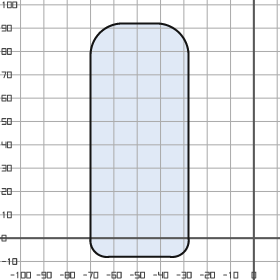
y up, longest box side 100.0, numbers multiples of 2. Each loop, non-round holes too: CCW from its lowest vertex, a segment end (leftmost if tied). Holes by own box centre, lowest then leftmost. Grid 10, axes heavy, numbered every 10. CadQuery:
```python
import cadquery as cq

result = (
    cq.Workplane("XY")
    .moveTo(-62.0, -8.0)
    .lineTo(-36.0, -8.0)
    .threePointArc((-30.0, -6.0), (-28.0, 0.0))
    .lineTo(-28.0, 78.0)
    .threePointArc((-32.0, 88.0), (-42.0, 92.0))
    .lineTo(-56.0, 92.0)
    .threePointArc((-66.0, 88.0), (-70.0, 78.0))
    .lineTo(-70.0, 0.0)
    .threePointArc((-68.0, -6.0), (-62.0, -8.0))
    .close()
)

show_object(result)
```